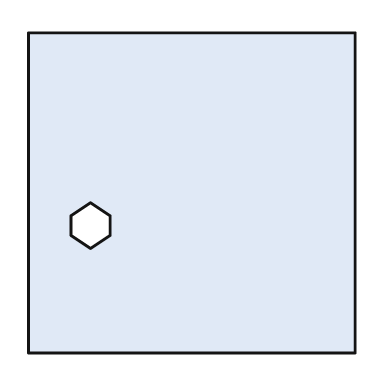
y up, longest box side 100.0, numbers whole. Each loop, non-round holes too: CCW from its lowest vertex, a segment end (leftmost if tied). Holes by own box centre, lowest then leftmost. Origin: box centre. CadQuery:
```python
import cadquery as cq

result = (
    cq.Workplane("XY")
    .moveTo(-50.0, -49.0)
    .lineTo(50.0, -49.0)
    .lineTo(50.0, 49.0)
    .lineTo(-50.0, 49.0)
    .close()
    .moveTo(-31.0, -17.0)
    .lineTo(-25.0, -13.0)
    .lineTo(-25.0, -7.0)
    .lineTo(-31.0, -3.0)
    .lineTo(-37.0, -7.0)
    .lineTo(-37.0, -13.0)
    .close()
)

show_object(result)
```